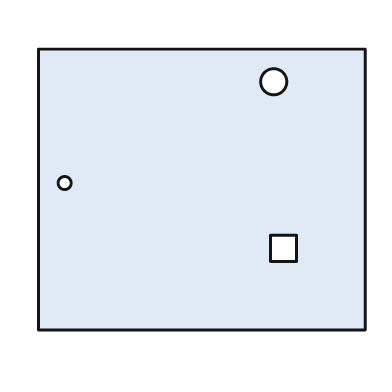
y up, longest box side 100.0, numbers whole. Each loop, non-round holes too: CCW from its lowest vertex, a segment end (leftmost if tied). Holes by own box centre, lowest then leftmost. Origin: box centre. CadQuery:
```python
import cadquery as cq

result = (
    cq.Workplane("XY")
    .moveTo(-50.0, -43.0)
    .lineTo(50.0, -43.0)
    .lineTo(50.0, 43.0)
    .lineTo(-50.0, 43.0)
    .close()
    .moveTo(21.0, -22.0)
    .lineTo(29.0, -22.0)
    .lineTo(29.0, -14.0)
    .lineTo(21.0, -14.0)
    .close()
    .moveTo(-42.0, 2.0)
    .circle(2.0)
    .moveTo(22.0, 33.0)
    .circle(4.0)
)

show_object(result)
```